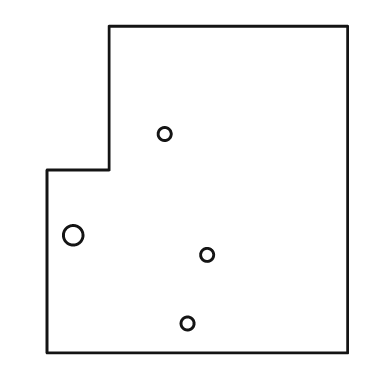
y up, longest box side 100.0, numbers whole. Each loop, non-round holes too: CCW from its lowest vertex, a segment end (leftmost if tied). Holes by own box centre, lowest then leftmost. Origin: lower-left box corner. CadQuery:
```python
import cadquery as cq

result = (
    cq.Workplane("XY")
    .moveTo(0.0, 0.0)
    .lineTo(92.0, 0.0)
    .lineTo(92.0, 100.0)
    .lineTo(19.0, 100.0)
    .lineTo(19.0, 56.0)
    .lineTo(0.0, 56.0)
    .close()
    .moveTo(43.0, 9.0)
    .circle(2.0)
    .moveTo(49.0, 30.0)
    .circle(2.0)
    .moveTo(8.0, 36.0)
    .circle(3.0)
    .moveTo(36.0, 67.0)
    .circle(2.0)
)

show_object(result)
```